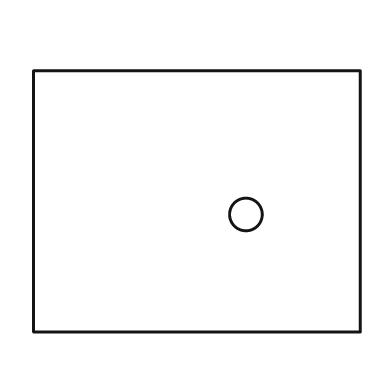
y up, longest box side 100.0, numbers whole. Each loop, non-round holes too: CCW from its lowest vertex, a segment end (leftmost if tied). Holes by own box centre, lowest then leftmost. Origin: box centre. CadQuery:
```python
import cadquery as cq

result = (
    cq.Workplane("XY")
    .moveTo(-50.0, -40.0)
    .lineTo(50.0, -40.0)
    .lineTo(50.0, 40.0)
    .lineTo(-50.0, 40.0)
    .close()
    .moveTo(15.0, -4.0)
    .circle(5.0)
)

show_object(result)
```